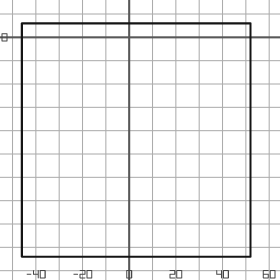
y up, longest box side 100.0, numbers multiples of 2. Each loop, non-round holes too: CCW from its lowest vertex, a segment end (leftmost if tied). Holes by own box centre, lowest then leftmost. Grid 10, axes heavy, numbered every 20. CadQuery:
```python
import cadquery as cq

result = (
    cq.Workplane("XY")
    .moveTo(-46.0, -94.0)
    .lineTo(52.0, -94.0)
    .lineTo(52.0, 6.0)
    .lineTo(-46.0, 6.0)
    .close()
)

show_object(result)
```